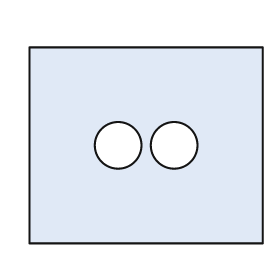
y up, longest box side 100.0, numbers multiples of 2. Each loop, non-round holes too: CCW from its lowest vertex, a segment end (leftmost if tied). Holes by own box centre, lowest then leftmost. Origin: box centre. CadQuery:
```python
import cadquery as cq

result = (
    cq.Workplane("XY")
    .moveTo(-50.0, -42.0)
    .lineTo(50.0, -42.0)
    .lineTo(50.0, 42.0)
    .lineTo(-50.0, 42.0)
    .close()
    .moveTo(-12.0, 0.0)
    .circle(10.0)
    .moveTo(12.0, 0.0)
    .circle(10.0)
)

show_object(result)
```